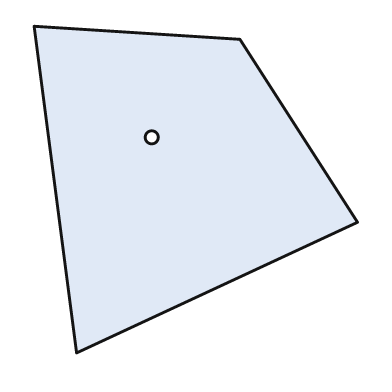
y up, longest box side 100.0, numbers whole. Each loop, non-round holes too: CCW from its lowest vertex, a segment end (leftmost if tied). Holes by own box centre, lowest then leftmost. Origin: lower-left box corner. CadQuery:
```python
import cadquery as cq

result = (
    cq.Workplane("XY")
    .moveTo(13.0, 0.0)
    .lineTo(99.0, 40.0)
    .lineTo(63.0, 96.0)
    .lineTo(0.0, 100.0)
    .close()
    .moveTo(36.0, 66.0)
    .circle(2.0)
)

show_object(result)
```